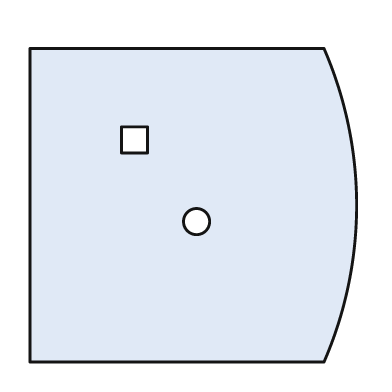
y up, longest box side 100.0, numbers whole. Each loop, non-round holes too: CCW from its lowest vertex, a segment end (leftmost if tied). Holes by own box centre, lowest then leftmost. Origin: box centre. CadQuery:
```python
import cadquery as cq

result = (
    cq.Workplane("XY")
    .moveTo(-50.0, -48.0)
    .lineTo(40.0, -48.0)
    .threePointArc((50.0, 0.0), (40.0, 48.0))
    .lineTo(-50.0, 48.0)
    .close()
    .moveTo(1.0, -5.0)
    .circle(4.0)
    .moveTo(-22.0, 16.0)
    .lineTo(-14.0, 16.0)
    .lineTo(-14.0, 24.0)
    .lineTo(-22.0, 24.0)
    .close()
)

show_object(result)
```